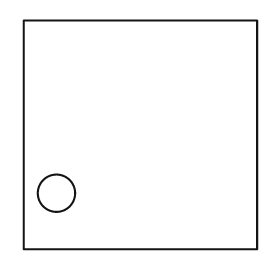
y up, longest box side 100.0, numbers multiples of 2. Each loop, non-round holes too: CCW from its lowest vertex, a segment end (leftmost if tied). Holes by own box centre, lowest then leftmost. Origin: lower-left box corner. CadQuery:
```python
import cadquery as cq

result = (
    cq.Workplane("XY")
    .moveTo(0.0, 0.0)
    .lineTo(100.0, 0.0)
    .lineTo(100.0, 98.0)
    .lineTo(0.0, 98.0)
    .close()
    .moveTo(14.0, 24.0)
    .circle(8.0)
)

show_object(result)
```